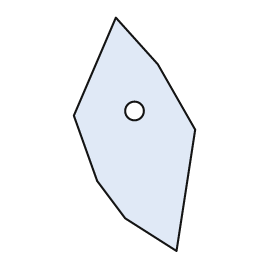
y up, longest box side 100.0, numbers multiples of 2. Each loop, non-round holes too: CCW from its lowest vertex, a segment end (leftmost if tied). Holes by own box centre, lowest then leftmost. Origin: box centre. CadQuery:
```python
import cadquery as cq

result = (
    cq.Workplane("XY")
    .moveTo(18.0, -50.0)
    .lineTo(26.0, 2.0)
    .lineTo(10.0, 30.0)
    .lineTo(-8.0, 50.0)
    .lineTo(-26.0, 8.0)
    .lineTo(-16.0, -20.0)
    .lineTo(-4.0, -36.0)
    .close()
    .moveTo(0.0, 10.0)
    .circle(4.0)
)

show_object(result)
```